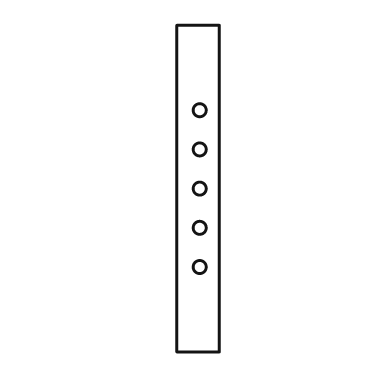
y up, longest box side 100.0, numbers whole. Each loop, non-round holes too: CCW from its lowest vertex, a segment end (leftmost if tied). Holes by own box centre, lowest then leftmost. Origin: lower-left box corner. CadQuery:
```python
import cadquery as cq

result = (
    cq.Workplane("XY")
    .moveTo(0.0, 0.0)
    .lineTo(13.0, 0.0)
    .lineTo(13.0, 100.0)
    .lineTo(0.0, 100.0)
    .close()
    .moveTo(7.0, 26.0)
    .circle(2.0)
    .moveTo(7.0, 38.0)
    .circle(2.0)
    .moveTo(7.0, 50.0)
    .circle(2.0)
    .moveTo(7.0, 62.0)
    .circle(2.0)
    .moveTo(7.0, 74.0)
    .circle(2.0)
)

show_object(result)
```